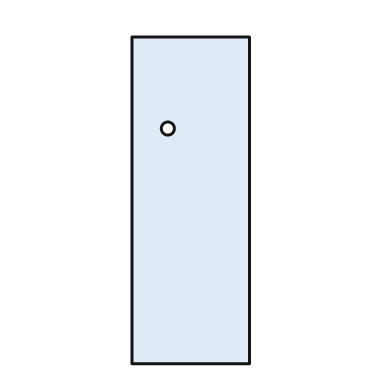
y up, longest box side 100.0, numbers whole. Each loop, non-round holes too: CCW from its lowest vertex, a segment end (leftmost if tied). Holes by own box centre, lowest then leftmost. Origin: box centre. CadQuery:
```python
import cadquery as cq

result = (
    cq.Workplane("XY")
    .moveTo(-18.0, -50.0)
    .lineTo(18.0, -50.0)
    .lineTo(18.0, 50.0)
    .lineTo(-18.0, 50.0)
    .close()
    .moveTo(-7.0, 22.0)
    .circle(2.0)
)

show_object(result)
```